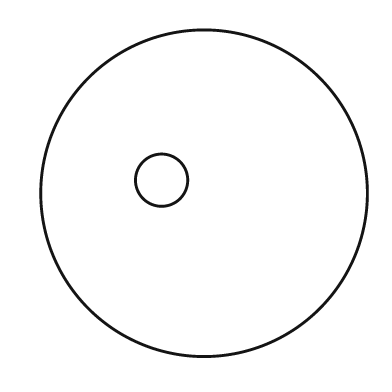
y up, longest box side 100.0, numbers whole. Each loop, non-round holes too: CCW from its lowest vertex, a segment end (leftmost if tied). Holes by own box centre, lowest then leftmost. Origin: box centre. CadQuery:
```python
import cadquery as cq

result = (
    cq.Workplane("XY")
    .moveTo(0.0, 0.0)
    .circle(50.0)
    .moveTo(-13.0, 4.0)
    .circle(8.0)
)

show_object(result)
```